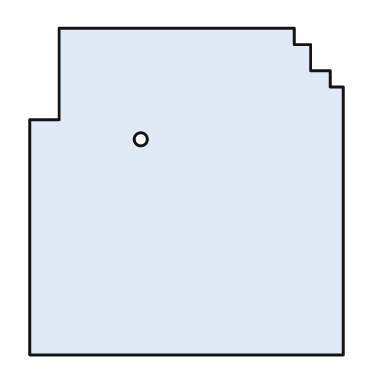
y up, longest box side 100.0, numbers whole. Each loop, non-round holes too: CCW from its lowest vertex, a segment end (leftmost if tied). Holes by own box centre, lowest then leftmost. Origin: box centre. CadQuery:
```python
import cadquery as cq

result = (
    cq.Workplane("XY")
    .moveTo(-48.0, -50.0)
    .lineTo(48.0, -50.0)
    .lineTo(48.0, 32.0)
    .lineTo(44.0, 32.0)
    .lineTo(44.0, 37.0)
    .lineTo(38.0, 37.0)
    .lineTo(38.0, 45.0)
    .lineTo(33.0, 45.0)
    .lineTo(33.0, 50.0)
    .lineTo(-39.0, 50.0)
    .lineTo(-39.0, 22.0)
    .lineTo(-48.0, 22.0)
    .close()
    .moveTo(-14.0, 16.0)
    .circle(2.0)
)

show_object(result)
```